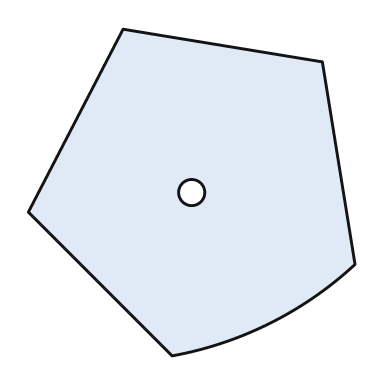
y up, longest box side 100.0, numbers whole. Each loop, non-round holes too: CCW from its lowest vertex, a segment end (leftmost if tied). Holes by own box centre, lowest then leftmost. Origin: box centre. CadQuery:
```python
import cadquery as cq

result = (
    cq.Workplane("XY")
    .moveTo(-6.0, -50.0)
    .threePointArc((24.0, -40.0), (50.0, -22.0))
    .lineTo(40.0, 40.0)
    .lineTo(-21.0, 50.0)
    .lineTo(-50.0, -6.0)
    .close()
    .moveTo(0.0, 0.0)
    .circle(4.0)
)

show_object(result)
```